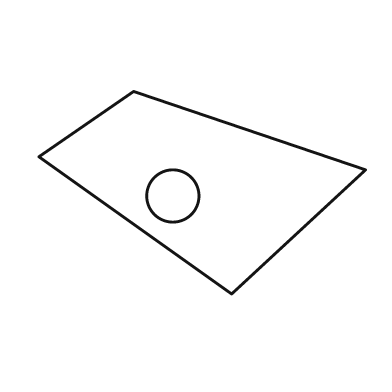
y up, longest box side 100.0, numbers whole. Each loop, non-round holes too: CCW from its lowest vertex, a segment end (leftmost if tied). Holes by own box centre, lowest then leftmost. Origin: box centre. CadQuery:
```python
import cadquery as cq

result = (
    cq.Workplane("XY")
    .moveTo(9.0, -31.0)
    .lineTo(50.0, 7.0)
    .lineTo(-21.0, 31.0)
    .lineTo(-50.0, 11.0)
    .close()
    .moveTo(-9.0, -1.0)
    .circle(8.0)
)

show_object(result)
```